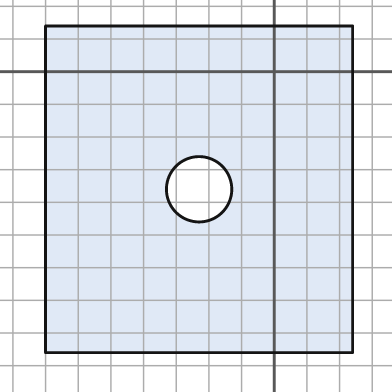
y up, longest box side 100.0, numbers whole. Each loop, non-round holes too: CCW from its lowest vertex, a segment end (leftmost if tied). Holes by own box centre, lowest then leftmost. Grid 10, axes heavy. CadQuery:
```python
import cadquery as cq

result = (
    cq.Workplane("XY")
    .moveTo(-70.0, -86.0)
    .lineTo(24.0, -86.0)
    .lineTo(24.0, 14.0)
    .lineTo(-70.0, 14.0)
    .close()
    .moveTo(-23.0, -36.0)
    .circle(10.0)
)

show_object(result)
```